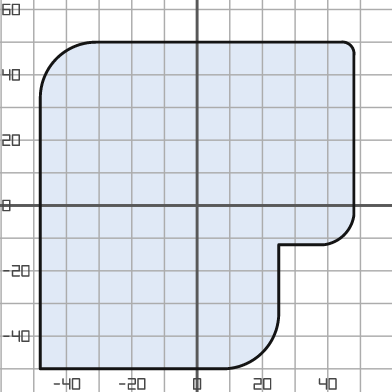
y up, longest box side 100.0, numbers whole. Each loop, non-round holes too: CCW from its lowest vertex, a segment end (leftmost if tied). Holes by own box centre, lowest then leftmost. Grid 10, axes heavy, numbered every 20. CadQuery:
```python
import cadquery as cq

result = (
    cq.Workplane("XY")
    .moveTo(-48.0, -50.0)
    .lineTo(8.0, -50.0)
    .threePointArc((20.0, -45.0), (25.0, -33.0))
    .lineTo(25.0, -12.0)
    .lineTo(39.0, -12.0)
    .threePointArc((45.0, -9.0), (48.0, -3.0))
    .lineTo(48.0, 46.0)
    .threePointArc((47.0, 49.0), (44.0, 50.0))
    .lineTo(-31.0, 50.0)
    .threePointArc((-43.0, 45.0), (-48.0, 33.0))
    .close()
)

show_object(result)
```